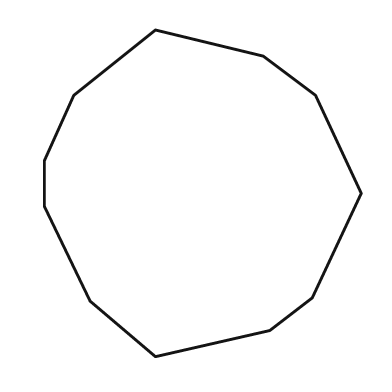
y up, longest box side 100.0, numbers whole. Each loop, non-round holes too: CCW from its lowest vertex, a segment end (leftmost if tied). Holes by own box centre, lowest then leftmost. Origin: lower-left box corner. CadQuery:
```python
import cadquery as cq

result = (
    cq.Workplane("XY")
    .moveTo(34.0, 0.0)
    .lineTo(69.0, 8.0)
    .lineTo(82.0, 18.0)
    .lineTo(97.0, 50.0)
    .lineTo(83.0, 80.0)
    .lineTo(67.0, 92.0)
    .lineTo(34.0, 100.0)
    .lineTo(9.0, 80.0)
    .lineTo(0.0, 60.0)
    .lineTo(0.0, 46.0)
    .lineTo(14.0, 17.0)
    .close()
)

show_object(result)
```